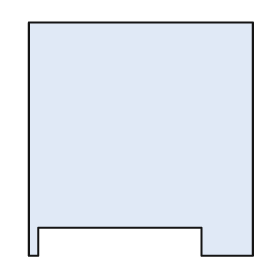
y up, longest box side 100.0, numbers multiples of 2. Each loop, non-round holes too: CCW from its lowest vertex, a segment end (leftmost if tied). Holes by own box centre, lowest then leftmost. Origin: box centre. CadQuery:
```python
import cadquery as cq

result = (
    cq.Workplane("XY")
    .moveTo(-48.0, -50.0)
    .lineTo(-44.0, -50.0)
    .lineTo(-44.0, -38.0)
    .lineTo(26.0, -38.0)
    .lineTo(26.0, -50.0)
    .lineTo(48.0, -50.0)
    .lineTo(48.0, 50.0)
    .lineTo(-48.0, 50.0)
    .close()
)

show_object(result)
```